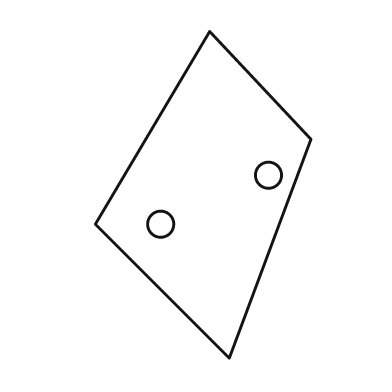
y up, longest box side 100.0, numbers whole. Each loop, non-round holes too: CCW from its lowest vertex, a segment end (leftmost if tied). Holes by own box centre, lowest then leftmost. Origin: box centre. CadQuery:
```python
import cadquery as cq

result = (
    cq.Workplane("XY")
    .moveTo(8.0, -50.0)
    .lineTo(33.0, 17.0)
    .lineTo(2.0, 50.0)
    .lineTo(-33.0, -9.0)
    .close()
    .moveTo(-13.0, -9.0)
    .circle(4.0)
    .moveTo(20.0, 6.0)
    .circle(4.0)
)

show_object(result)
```